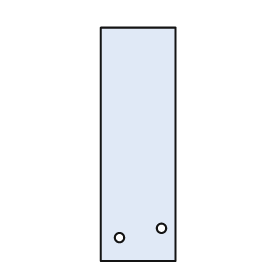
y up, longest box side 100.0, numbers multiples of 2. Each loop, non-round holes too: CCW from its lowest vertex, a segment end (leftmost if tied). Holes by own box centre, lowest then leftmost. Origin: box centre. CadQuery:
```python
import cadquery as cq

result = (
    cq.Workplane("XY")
    .moveTo(-16.0, -50.0)
    .lineTo(16.0, -50.0)
    .lineTo(16.0, 50.0)
    .lineTo(-16.0, 50.0)
    .close()
    .moveTo(-8.0, -40.0)
    .circle(2.0)
    .moveTo(10.0, -36.0)
    .circle(2.0)
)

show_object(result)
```